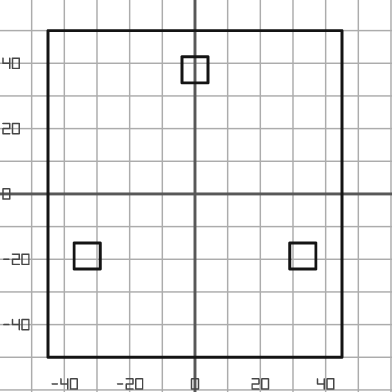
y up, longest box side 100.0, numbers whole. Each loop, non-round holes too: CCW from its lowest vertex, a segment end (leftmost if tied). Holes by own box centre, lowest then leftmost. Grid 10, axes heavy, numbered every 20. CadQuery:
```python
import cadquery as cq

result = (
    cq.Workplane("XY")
    .moveTo(-45.0, -50.0)
    .lineTo(45.0, -50.0)
    .lineTo(45.0, 50.0)
    .lineTo(-45.0, 50.0)
    .close()
    .moveTo(-37.0, -23.0)
    .lineTo(-29.0, -23.0)
    .lineTo(-29.0, -15.0)
    .lineTo(-37.0, -15.0)
    .close()
    .moveTo(29.0, -23.0)
    .lineTo(37.0, -23.0)
    .lineTo(37.0, -15.0)
    .lineTo(29.0, -15.0)
    .close()
    .moveTo(-4.0, 34.0)
    .lineTo(4.0, 34.0)
    .lineTo(4.0, 42.0)
    .lineTo(-4.0, 42.0)
    .close()
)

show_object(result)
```